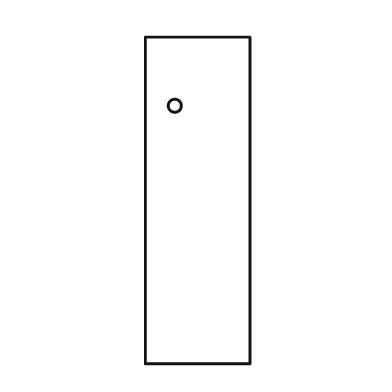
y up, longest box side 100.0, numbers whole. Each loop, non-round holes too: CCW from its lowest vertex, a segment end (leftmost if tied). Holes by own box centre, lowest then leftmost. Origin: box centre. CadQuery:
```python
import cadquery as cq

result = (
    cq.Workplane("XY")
    .moveTo(-16.0, -50.0)
    .lineTo(16.0, -50.0)
    .lineTo(16.0, 50.0)
    .lineTo(-16.0, 50.0)
    .close()
    .moveTo(-7.0, 29.0)
    .circle(2.0)
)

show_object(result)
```